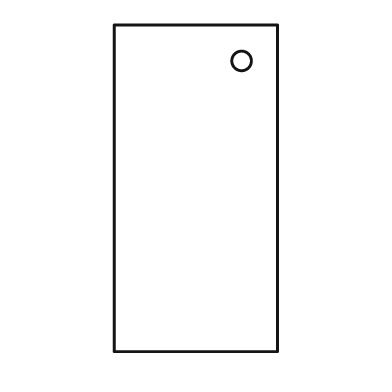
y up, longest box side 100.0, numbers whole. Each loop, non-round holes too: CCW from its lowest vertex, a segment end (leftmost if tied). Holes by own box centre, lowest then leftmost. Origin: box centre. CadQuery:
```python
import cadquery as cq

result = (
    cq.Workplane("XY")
    .moveTo(-25.0, -50.0)
    .lineTo(25.0, -50.0)
    .lineTo(25.0, 50.0)
    .lineTo(-25.0, 50.0)
    .close()
    .moveTo(14.0, 39.0)
    .circle(3.0)
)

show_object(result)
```